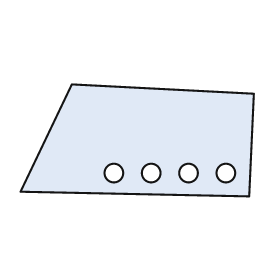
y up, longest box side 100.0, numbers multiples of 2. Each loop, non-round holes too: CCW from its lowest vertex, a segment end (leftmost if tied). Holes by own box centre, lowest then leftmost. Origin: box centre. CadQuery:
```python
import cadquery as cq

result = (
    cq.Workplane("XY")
    .moveTo(48.0, -24.0)
    .lineTo(50.0, 20.0)
    .lineTo(-28.0, 24.0)
    .lineTo(-50.0, -22.0)
    .close()
    .moveTo(-10.0, -14.0)
    .circle(4.0)
    .moveTo(6.0, -14.0)
    .circle(4.0)
    .moveTo(22.0, -14.0)
    .circle(4.0)
    .moveTo(38.0, -14.0)
    .circle(4.0)
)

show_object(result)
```